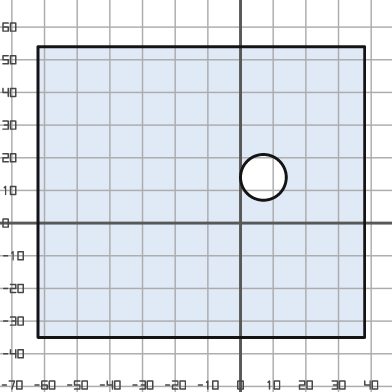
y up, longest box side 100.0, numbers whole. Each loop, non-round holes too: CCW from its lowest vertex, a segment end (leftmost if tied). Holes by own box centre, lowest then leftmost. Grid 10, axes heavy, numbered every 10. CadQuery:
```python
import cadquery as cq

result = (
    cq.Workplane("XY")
    .moveTo(-62.0, -35.0)
    .lineTo(38.0, -35.0)
    .lineTo(38.0, 54.0)
    .lineTo(-62.0, 54.0)
    .close()
    .moveTo(7.0, 14.0)
    .circle(7.0)
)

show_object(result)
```